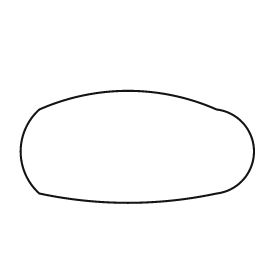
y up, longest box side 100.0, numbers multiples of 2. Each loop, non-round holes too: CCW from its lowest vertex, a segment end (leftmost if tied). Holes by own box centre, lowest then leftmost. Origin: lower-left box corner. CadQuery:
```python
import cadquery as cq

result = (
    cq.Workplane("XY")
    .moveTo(8.0, 4.0)
    .threePointArc((46.0, 0.0), (84.0, 4.0))
    .threePointArc((100.0, 22.0), (84.0, 40.0))
    .threePointArc((46.0, 48.0), (8.0, 40.0))
    .threePointArc((0.0, 22.0), (8.0, 4.0))
    .close()
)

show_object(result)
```